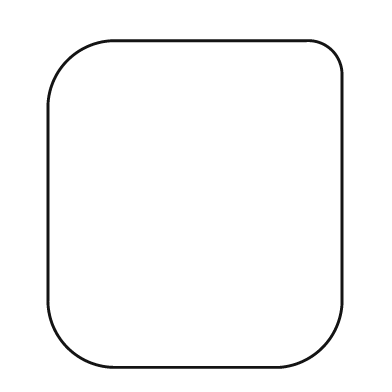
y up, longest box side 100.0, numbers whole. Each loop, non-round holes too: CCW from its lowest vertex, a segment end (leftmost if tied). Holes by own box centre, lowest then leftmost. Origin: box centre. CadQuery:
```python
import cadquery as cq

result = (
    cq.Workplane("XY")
    .moveTo(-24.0, -50.0)
    .lineTo(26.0, -50.0)
    .threePointArc((39.0, -44.0), (45.0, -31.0))
    .lineTo(45.0, 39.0)
    .threePointArc((42.0, 47.0), (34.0, 50.0))
    .lineTo(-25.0, 50.0)
    .threePointArc((-39.0, 44.0), (-45.0, 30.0))
    .lineTo(-45.0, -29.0)
    .threePointArc((-39.0, -44.0), (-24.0, -50.0))
    .close()
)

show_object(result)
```